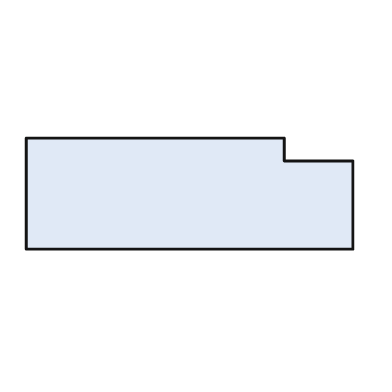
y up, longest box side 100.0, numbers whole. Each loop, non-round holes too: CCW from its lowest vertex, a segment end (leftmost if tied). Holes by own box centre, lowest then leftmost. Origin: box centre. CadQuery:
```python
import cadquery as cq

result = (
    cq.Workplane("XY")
    .moveTo(-50.0, -17.0)
    .lineTo(50.0, -17.0)
    .lineTo(50.0, 10.0)
    .lineTo(29.0, 10.0)
    .lineTo(29.0, 17.0)
    .lineTo(-50.0, 17.0)
    .close()
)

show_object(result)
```